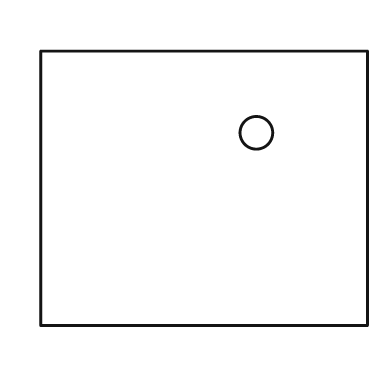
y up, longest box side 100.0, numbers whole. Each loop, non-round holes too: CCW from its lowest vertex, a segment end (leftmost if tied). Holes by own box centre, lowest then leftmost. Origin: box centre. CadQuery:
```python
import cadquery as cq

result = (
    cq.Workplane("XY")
    .moveTo(-50.0, -42.0)
    .lineTo(50.0, -42.0)
    .lineTo(50.0, 42.0)
    .lineTo(-50.0, 42.0)
    .close()
    .moveTo(16.0, 17.0)
    .circle(5.0)
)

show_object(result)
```